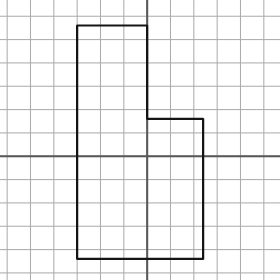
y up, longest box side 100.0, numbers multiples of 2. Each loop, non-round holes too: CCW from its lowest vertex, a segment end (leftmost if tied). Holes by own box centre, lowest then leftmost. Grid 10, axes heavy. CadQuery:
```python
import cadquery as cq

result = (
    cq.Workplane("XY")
    .moveTo(-30.0, -44.0)
    .lineTo(24.0, -44.0)
    .lineTo(24.0, 16.0)
    .lineTo(0.0, 16.0)
    .lineTo(0.0, 56.0)
    .lineTo(-30.0, 56.0)
    .close()
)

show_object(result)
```